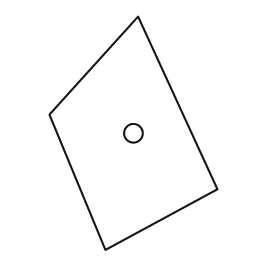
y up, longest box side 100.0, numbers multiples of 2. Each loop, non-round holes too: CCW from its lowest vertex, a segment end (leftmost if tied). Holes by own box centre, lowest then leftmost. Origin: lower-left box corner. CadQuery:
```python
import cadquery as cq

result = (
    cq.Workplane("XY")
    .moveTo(24.0, 0.0)
    .lineTo(72.0, 26.0)
    .lineTo(38.0, 100.0)
    .lineTo(0.0, 58.0)
    .close()
    .moveTo(36.0, 50.0)
    .circle(4.0)
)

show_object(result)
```